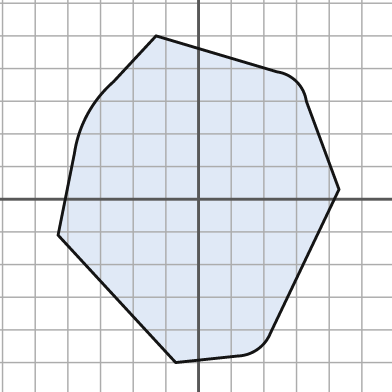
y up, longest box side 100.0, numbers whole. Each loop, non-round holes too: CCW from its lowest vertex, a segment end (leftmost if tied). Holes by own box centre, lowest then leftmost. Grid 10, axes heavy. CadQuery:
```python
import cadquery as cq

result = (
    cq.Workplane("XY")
    .moveTo(-7.0, -50.0)
    .lineTo(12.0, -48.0)
    .threePointArc((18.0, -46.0), (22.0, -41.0))
    .lineTo(43.0, 3.0)
    .lineTo(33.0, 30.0)
    .threePointArc((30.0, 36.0), (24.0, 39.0))
    .lineTo(-13.0, 50.0)
    .lineTo(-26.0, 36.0)
    .threePointArc((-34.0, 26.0), (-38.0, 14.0))
    .lineTo(-43.0, -11.0)
    .close()
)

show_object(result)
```